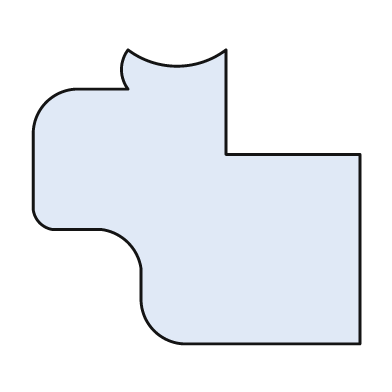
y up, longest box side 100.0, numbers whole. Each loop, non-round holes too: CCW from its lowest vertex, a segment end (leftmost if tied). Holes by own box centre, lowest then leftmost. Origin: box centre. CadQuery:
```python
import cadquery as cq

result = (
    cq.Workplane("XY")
    .moveTo(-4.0, -45.0)
    .lineTo(50.0, -45.0)
    .lineTo(50.0, 13.0)
    .lineTo(9.0, 13.0)
    .lineTo(9.0, 45.0)
    .threePointArc((-6.0, 40.0), (-21.0, 45.0))
    .threePointArc((-23.0, 39.0), (-21.0, 33.0))
    .lineTo(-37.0, 33.0)
    .threePointArc((-46.0, 29.0), (-50.0, 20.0))
    .lineTo(-50.0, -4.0)
    .threePointArc((-48.0, -8.0), (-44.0, -10.0))
    .lineTo(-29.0, -10.0)
    .threePointArc((-21.0, -14.0), (-17.0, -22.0))
    .lineTo(-17.0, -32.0)
    .threePointArc((-13.0, -41.0), (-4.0, -45.0))
    .close()
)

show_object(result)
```